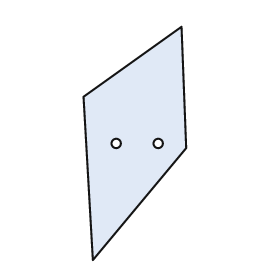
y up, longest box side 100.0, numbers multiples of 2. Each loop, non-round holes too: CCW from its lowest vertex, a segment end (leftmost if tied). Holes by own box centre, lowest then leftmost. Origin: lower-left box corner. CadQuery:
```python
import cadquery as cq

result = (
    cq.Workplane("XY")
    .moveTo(4.0, 0.0)
    .lineTo(44.0, 48.0)
    .lineTo(42.0, 100.0)
    .lineTo(0.0, 70.0)
    .close()
    .moveTo(14.0, 50.0)
    .circle(2.0)
    .moveTo(32.0, 50.0)
    .circle(2.0)
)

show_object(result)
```